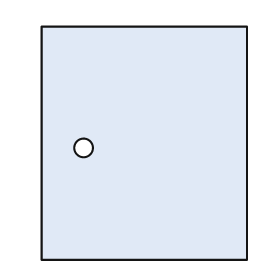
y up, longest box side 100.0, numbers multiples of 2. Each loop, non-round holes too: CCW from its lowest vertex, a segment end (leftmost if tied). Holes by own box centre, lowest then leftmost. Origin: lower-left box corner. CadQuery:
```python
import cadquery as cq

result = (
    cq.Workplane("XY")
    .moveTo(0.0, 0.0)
    .lineTo(88.0, 0.0)
    .lineTo(88.0, 100.0)
    .lineTo(0.0, 100.0)
    .close()
    .moveTo(18.0, 48.0)
    .circle(4.0)
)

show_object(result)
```